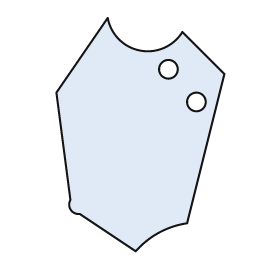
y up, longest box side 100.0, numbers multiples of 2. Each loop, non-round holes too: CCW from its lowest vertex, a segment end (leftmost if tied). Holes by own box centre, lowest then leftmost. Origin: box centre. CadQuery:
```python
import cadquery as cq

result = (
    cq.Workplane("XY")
    .moveTo(-2.0, -50.0)
    .threePointArc((8.0, -42.0), (20.0, -38.0))
    .lineTo(36.0, 26.0)
    .lineTo(18.0, 44.0)
    .threePointArc((0.0, 36.0), (-14.0, 50.0))
    .lineTo(-36.0, 18.0)
    .lineTo(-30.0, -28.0)
    .threePointArc((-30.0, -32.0), (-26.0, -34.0))
    .close()
    .moveTo(24.0, 14.0)
    .circle(4.0)
    .moveTo(12.0, 28.0)
    .circle(4.0)
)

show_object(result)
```